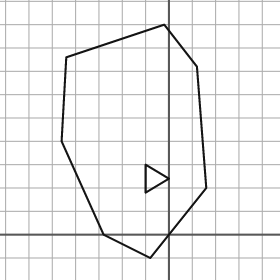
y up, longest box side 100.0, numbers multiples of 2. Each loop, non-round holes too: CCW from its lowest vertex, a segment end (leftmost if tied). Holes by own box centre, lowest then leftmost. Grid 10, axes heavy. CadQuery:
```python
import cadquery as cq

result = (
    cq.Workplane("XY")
    .moveTo(-8.0, -10.0)
    .lineTo(16.0, 20.0)
    .lineTo(12.0, 72.0)
    .lineTo(-2.0, 90.0)
    .lineTo(-44.0, 76.0)
    .lineTo(-46.0, 40.0)
    .lineTo(-28.0, 0.0)
    .close()
    .moveTo(-10.0, 18.0)
    .lineTo(0.0, 24.0)
    .lineTo(-10.0, 30.0)
    .close()
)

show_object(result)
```